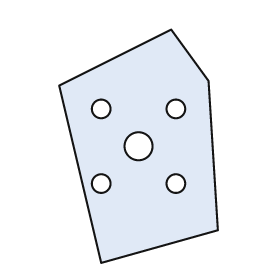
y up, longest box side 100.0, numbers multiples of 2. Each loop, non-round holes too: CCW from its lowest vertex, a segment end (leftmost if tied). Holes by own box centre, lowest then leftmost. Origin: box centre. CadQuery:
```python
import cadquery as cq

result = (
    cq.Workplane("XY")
    .moveTo(-16.0, -50.0)
    .lineTo(34.0, -36.0)
    .lineTo(30.0, 28.0)
    .lineTo(14.0, 50.0)
    .lineTo(-34.0, 26.0)
    .close()
    .moveTo(-16.0, -16.0)
    .circle(4.0)
    .moveTo(16.0, -16.0)
    .circle(4.0)
    .moveTo(0.0, 0.0)
    .circle(6.0)
    .moveTo(-16.0, 16.0)
    .circle(4.0)
    .moveTo(16.0, 16.0)
    .circle(4.0)
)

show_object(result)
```